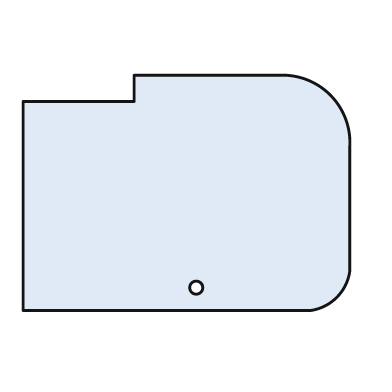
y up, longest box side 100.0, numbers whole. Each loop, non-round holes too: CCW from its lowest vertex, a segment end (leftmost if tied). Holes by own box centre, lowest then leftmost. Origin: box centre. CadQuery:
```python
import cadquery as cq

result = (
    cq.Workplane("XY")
    .moveTo(-50.0, -36.0)
    .lineTo(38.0, -36.0)
    .threePointArc((46.0, -32.0), (50.0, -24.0))
    .lineTo(50.0, 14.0)
    .threePointArc((44.0, 30.0), (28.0, 36.0))
    .lineTo(-16.0, 36.0)
    .lineTo(-16.0, 28.0)
    .lineTo(-50.0, 28.0)
    .close()
    .moveTo(3.0, -29.0)
    .circle(2.0)
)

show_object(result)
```